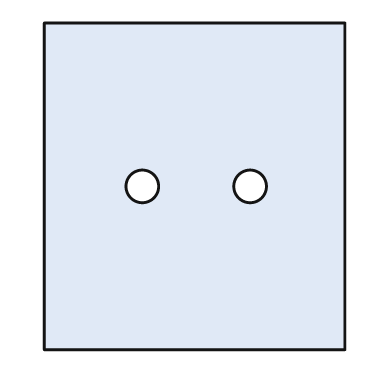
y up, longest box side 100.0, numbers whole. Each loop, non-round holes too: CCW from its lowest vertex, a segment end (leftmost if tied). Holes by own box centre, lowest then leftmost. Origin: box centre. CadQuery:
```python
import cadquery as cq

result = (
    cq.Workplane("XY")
    .moveTo(-46.0, -50.0)
    .lineTo(46.0, -50.0)
    .lineTo(46.0, 50.0)
    .lineTo(-46.0, 50.0)
    .close()
    .moveTo(-16.0, 0.0)
    .circle(5.0)
    .moveTo(17.0, 0.0)
    .circle(5.0)
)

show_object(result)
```